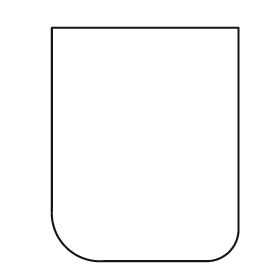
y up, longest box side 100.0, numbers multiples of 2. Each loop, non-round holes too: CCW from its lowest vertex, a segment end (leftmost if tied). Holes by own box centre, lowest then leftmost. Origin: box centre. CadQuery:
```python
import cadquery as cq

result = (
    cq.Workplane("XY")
    .moveTo(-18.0, -50.0)
    .lineTo(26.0, -50.0)
    .threePointArc((36.0, -46.0), (40.0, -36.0))
    .lineTo(40.0, 50.0)
    .lineTo(-40.0, 50.0)
    .lineTo(-40.0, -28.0)
    .threePointArc((-34.0, -44.0), (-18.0, -50.0))
    .close()
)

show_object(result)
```